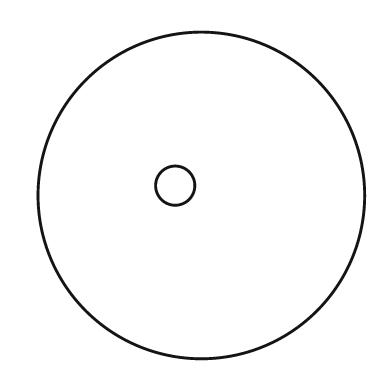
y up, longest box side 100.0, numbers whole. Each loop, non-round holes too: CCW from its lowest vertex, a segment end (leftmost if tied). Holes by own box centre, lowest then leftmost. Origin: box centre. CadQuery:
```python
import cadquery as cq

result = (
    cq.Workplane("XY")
    .moveTo(0.0, 0.0)
    .circle(50.0)
    .moveTo(-8.0, 3.0)
    .circle(6.0)
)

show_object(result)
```